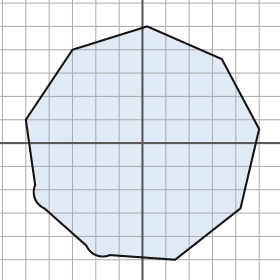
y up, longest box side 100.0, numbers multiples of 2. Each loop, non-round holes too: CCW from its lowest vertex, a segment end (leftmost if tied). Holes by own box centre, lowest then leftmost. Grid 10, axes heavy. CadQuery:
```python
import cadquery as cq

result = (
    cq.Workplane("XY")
    .moveTo(14.0, -50.0)
    .lineTo(42.0, -28.0)
    .lineTo(50.0, 6.0)
    .lineTo(34.0, 36.0)
    .lineTo(2.0, 50.0)
    .lineTo(-30.0, 40.0)
    .lineTo(-50.0, 10.0)
    .lineTo(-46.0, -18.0)
    .threePointArc((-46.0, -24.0), (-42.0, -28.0))
    .lineTo(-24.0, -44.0)
    .threePointArc((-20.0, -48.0), (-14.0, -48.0))
    .close()
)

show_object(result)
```